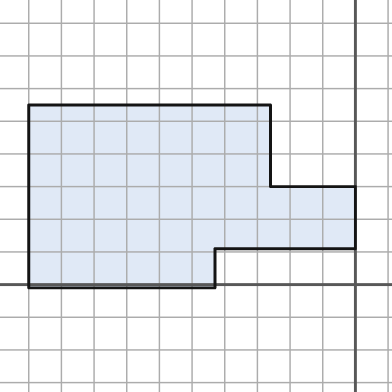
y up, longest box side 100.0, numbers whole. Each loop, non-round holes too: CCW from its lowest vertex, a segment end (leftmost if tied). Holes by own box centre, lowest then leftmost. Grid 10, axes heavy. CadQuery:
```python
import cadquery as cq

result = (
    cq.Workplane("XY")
    .moveTo(-100.0, -1.0)
    .lineTo(-43.0, -1.0)
    .lineTo(-43.0, 11.0)
    .lineTo(0.0, 11.0)
    .lineTo(0.0, 30.0)
    .lineTo(-26.0, 30.0)
    .lineTo(-26.0, 55.0)
    .lineTo(-100.0, 55.0)
    .close()
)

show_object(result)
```